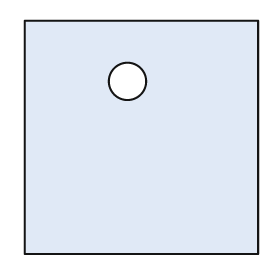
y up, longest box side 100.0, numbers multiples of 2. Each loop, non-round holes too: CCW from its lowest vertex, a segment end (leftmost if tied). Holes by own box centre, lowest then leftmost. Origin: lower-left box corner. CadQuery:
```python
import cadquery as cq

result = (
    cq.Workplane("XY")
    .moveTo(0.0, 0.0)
    .lineTo(100.0, 0.0)
    .lineTo(100.0, 100.0)
    .lineTo(0.0, 100.0)
    .close()
    .moveTo(44.0, 74.0)
    .circle(8.0)
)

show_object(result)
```